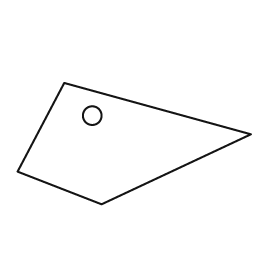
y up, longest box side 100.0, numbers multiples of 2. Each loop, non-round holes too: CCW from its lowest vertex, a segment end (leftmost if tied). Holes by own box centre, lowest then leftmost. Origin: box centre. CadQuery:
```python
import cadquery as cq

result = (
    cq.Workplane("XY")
    .moveTo(-14.0, -26.0)
    .lineTo(50.0, 4.0)
    .lineTo(-30.0, 26.0)
    .lineTo(-50.0, -12.0)
    .close()
    .moveTo(-18.0, 12.0)
    .circle(4.0)
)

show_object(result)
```